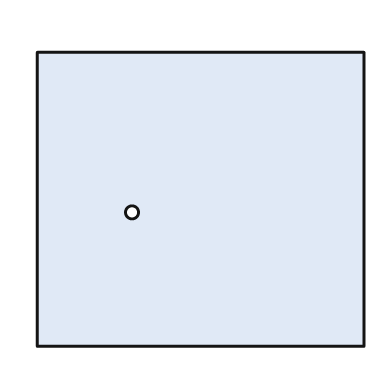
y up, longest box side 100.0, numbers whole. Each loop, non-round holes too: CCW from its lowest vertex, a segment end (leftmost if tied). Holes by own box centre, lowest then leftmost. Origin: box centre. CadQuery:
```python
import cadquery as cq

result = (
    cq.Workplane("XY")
    .moveTo(-50.0, -45.0)
    .lineTo(50.0, -45.0)
    .lineTo(50.0, 45.0)
    .lineTo(-50.0, 45.0)
    .close()
    .moveTo(-21.0, -4.0)
    .circle(2.0)
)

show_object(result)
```